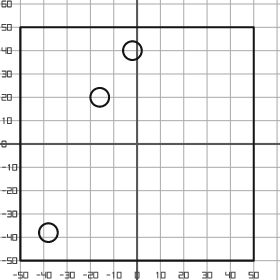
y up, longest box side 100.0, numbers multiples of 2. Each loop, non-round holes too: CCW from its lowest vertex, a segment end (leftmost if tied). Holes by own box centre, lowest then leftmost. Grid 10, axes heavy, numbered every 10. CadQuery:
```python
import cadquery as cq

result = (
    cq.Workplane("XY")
    .moveTo(-50.0, -50.0)
    .lineTo(50.0, -50.0)
    .lineTo(50.0, 50.0)
    .lineTo(-50.0, 50.0)
    .close()
    .moveTo(-38.0, -38.0)
    .circle(4.0)
    .moveTo(-16.0, 20.0)
    .circle(4.0)
    .moveTo(-2.0, 40.0)
    .circle(4.0)
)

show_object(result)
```